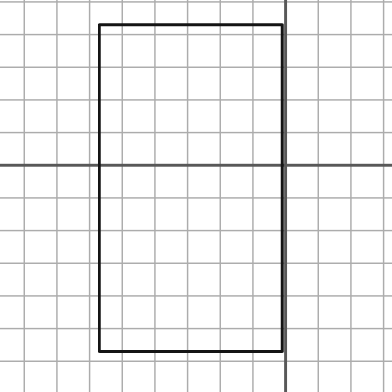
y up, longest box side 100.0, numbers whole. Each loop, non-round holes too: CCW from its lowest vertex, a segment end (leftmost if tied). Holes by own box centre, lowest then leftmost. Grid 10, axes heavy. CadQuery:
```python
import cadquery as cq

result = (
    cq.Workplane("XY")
    .moveTo(-57.0, -57.0)
    .lineTo(-1.0, -57.0)
    .lineTo(-1.0, 43.0)
    .lineTo(-57.0, 43.0)
    .close()
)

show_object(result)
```